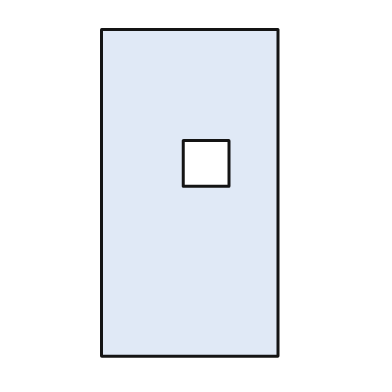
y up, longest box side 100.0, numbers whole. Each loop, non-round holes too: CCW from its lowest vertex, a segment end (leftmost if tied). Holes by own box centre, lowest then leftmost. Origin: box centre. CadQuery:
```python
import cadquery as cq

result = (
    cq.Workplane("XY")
    .moveTo(-27.0, -50.0)
    .lineTo(27.0, -50.0)
    .lineTo(27.0, 50.0)
    .lineTo(-27.0, 50.0)
    .close()
    .moveTo(-2.0, 2.0)
    .lineTo(12.0, 2.0)
    .lineTo(12.0, 16.0)
    .lineTo(-2.0, 16.0)
    .close()
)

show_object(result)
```